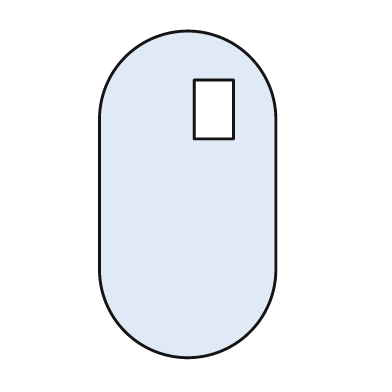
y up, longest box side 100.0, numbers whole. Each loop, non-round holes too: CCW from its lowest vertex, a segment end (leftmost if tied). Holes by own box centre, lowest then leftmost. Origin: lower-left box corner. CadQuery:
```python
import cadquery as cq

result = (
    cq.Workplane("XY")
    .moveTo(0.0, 27.0)
    .threePointArc((27.0, 0.0), (54.0, 27.0))
    .lineTo(54.0, 73.0)
    .threePointArc((27.0, 100.0), (0.0, 73.0))
    .close()
    .moveTo(29.0, 67.0)
    .lineTo(41.0, 67.0)
    .lineTo(41.0, 85.0)
    .lineTo(29.0, 85.0)
    .close()
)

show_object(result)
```